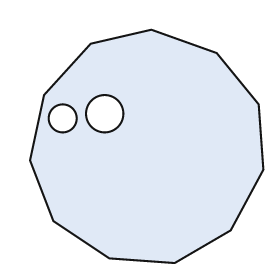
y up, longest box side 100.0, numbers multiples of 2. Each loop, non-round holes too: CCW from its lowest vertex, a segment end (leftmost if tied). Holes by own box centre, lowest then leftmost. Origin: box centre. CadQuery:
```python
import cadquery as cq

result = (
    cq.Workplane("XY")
    .moveTo(12.0, -50.0)
    .lineTo(36.0, -36.0)
    .lineTo(50.0, -10.0)
    .lineTo(48.0, 18.0)
    .lineTo(30.0, 40.0)
    .lineTo(2.0, 50.0)
    .lineTo(-24.0, 44.0)
    .lineTo(-44.0, 22.0)
    .lineTo(-50.0, -6.0)
    .lineTo(-40.0, -32.0)
    .lineTo(-16.0, -48.0)
    .close()
    .moveTo(-36.0, 12.0)
    .circle(6.0)
    .moveTo(-18.0, 14.0)
    .circle(8.0)
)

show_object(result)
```